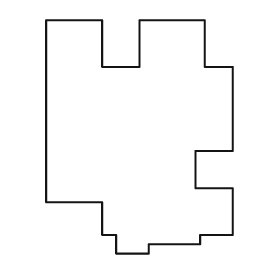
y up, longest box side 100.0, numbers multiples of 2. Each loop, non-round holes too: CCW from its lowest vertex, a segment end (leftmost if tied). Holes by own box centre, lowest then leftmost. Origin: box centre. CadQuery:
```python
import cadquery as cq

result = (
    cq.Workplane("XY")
    .moveTo(-10.0, -50.0)
    .lineTo(4.0, -50.0)
    .lineTo(4.0, -46.0)
    .lineTo(26.0, -46.0)
    .lineTo(26.0, -42.0)
    .lineTo(40.0, -42.0)
    .lineTo(40.0, -22.0)
    .lineTo(24.0, -22.0)
    .lineTo(24.0, -6.0)
    .lineTo(40.0, -6.0)
    .lineTo(40.0, 30.0)
    .lineTo(28.0, 30.0)
    .lineTo(28.0, 50.0)
    .lineTo(0.0, 50.0)
    .lineTo(0.0, 30.0)
    .lineTo(-16.0, 30.0)
    .lineTo(-16.0, 50.0)
    .lineTo(-40.0, 50.0)
    .lineTo(-40.0, -28.0)
    .lineTo(-16.0, -28.0)
    .lineTo(-16.0, -42.0)
    .lineTo(-10.0, -42.0)
    .close()
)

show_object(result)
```